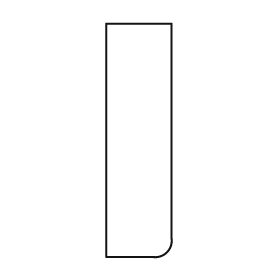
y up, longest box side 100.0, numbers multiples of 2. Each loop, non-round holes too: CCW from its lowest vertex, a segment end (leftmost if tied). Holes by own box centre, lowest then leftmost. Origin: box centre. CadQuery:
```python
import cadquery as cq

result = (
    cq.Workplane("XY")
    .moveTo(-14.0, -50.0)
    .lineTo(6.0, -50.0)
    .threePointArc((12.0, -48.0), (14.0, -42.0))
    .lineTo(14.0, 50.0)
    .lineTo(-14.0, 50.0)
    .close()
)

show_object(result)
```